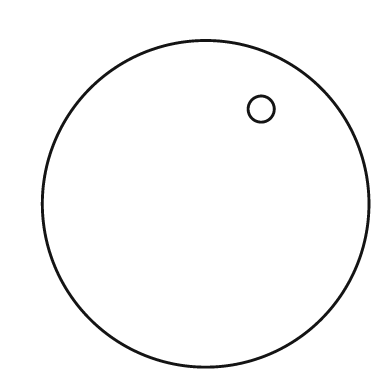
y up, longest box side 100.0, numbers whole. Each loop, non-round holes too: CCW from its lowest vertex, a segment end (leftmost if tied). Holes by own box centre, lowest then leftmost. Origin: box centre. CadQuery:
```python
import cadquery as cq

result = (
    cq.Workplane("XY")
    .moveTo(0.0, 0.0)
    .circle(50.0)
    .moveTo(17.0, 29.0)
    .circle(4.0)
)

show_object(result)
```